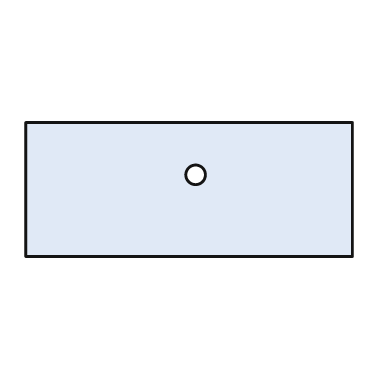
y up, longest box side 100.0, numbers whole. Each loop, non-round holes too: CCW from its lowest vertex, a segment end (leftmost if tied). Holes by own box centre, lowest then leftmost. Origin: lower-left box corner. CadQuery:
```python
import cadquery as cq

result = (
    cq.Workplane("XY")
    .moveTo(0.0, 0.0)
    .lineTo(100.0, 0.0)
    .lineTo(100.0, 41.0)
    .lineTo(0.0, 41.0)
    .close()
    .moveTo(52.0, 25.0)
    .circle(3.0)
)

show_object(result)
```